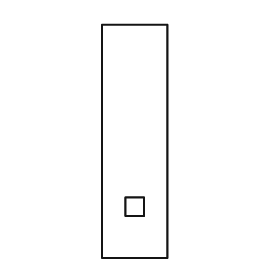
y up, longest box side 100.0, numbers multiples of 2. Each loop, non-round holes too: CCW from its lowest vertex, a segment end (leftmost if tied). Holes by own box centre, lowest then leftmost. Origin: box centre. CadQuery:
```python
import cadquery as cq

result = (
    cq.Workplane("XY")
    .moveTo(-14.0, -50.0)
    .lineTo(14.0, -50.0)
    .lineTo(14.0, 50.0)
    .lineTo(-14.0, 50.0)
    .close()
    .moveTo(-4.0, -32.0)
    .lineTo(4.0, -32.0)
    .lineTo(4.0, -24.0)
    .lineTo(-4.0, -24.0)
    .close()
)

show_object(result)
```